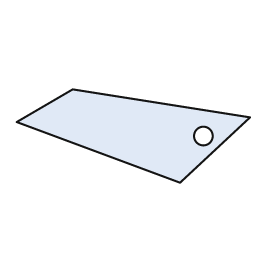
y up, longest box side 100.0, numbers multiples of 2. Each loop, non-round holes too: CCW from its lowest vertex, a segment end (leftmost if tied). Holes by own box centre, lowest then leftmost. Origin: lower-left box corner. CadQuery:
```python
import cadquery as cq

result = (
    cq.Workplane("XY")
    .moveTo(70.0, 0.0)
    .lineTo(100.0, 28.0)
    .lineTo(24.0, 40.0)
    .lineTo(0.0, 26.0)
    .close()
    .moveTo(80.0, 20.0)
    .circle(4.0)
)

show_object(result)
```